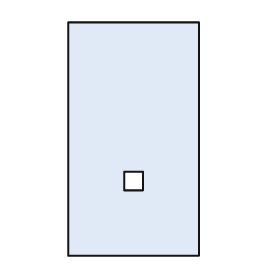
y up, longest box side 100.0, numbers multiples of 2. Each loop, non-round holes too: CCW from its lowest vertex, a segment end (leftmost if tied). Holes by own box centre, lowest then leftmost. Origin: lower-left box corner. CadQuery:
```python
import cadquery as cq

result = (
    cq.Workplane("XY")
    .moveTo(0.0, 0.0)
    .lineTo(56.0, 0.0)
    .lineTo(56.0, 100.0)
    .lineTo(0.0, 100.0)
    .close()
    .moveTo(24.0, 28.0)
    .lineTo(32.0, 28.0)
    .lineTo(32.0, 36.0)
    .lineTo(24.0, 36.0)
    .close()
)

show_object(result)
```